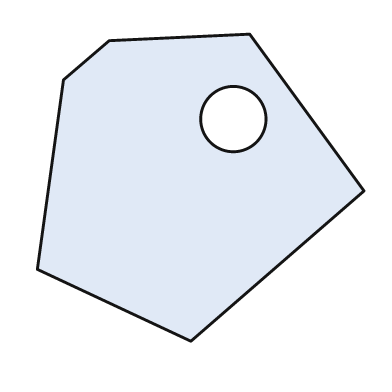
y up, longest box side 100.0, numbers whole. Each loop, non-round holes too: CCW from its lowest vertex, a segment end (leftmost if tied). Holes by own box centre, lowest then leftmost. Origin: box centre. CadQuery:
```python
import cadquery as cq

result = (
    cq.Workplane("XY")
    .moveTo(-3.0, -47.0)
    .lineTo(50.0, -1.0)
    .lineTo(15.0, 47.0)
    .lineTo(-28.0, 45.0)
    .lineTo(-42.0, 33.0)
    .lineTo(-50.0, -25.0)
    .close()
    .moveTo(10.0, 21.0)
    .circle(10.0)
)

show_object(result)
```